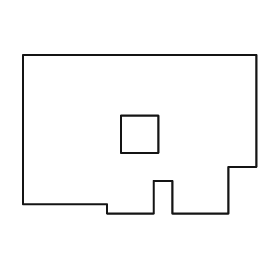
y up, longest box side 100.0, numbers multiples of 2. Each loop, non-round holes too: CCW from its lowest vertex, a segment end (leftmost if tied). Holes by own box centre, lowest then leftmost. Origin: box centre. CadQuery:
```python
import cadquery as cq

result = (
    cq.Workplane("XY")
    .moveTo(-14.0, -34.0)
    .lineTo(6.0, -34.0)
    .lineTo(6.0, -20.0)
    .lineTo(14.0, -20.0)
    .lineTo(14.0, -34.0)
    .lineTo(38.0, -34.0)
    .lineTo(38.0, -14.0)
    .lineTo(50.0, -14.0)
    .lineTo(50.0, 34.0)
    .lineTo(-50.0, 34.0)
    .lineTo(-50.0, -30.0)
    .lineTo(-14.0, -30.0)
    .close()
    .moveTo(-8.0, -8.0)
    .lineTo(8.0, -8.0)
    .lineTo(8.0, 8.0)
    .lineTo(-8.0, 8.0)
    .close()
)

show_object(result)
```